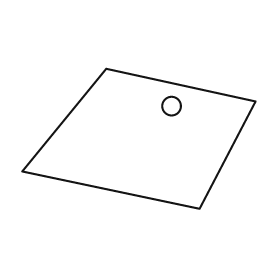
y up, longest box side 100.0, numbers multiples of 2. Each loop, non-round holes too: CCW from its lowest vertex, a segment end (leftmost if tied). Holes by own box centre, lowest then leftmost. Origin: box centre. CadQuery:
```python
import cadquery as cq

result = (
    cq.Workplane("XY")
    .moveTo(26.0, -30.0)
    .lineTo(50.0, 16.0)
    .lineTo(-14.0, 30.0)
    .lineTo(-50.0, -14.0)
    .close()
    .moveTo(14.0, 14.0)
    .circle(4.0)
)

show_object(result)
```